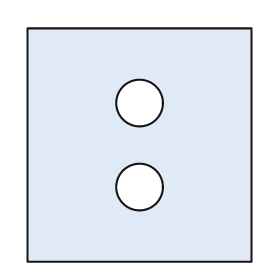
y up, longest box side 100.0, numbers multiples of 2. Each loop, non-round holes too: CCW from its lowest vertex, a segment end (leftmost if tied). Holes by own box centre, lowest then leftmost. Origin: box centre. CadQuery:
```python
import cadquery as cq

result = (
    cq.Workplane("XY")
    .moveTo(-48.0, -50.0)
    .lineTo(48.0, -50.0)
    .lineTo(48.0, 50.0)
    .lineTo(-48.0, 50.0)
    .close()
    .moveTo(0.0, -18.0)
    .circle(10.0)
    .moveTo(0.0, 18.0)
    .circle(10.0)
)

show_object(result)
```